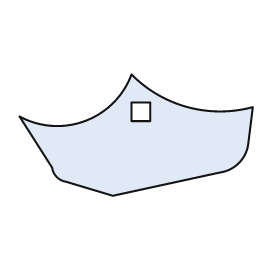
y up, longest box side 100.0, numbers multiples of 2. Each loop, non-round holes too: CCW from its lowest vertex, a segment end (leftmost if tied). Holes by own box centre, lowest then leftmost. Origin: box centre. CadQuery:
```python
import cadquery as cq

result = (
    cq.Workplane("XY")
    .moveTo(-10.0, -26.0)
    .lineTo(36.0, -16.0)
    .threePointArc((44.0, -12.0), (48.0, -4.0))
    .lineTo(50.0, 12.0)
    .threePointArc((22.0, 12.0), (-2.0, 26.0))
    .threePointArc((-22.0, 6.0), (-50.0, 8.0))
    .lineTo(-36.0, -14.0)
    .threePointArc((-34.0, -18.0), (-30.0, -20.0))
    .close()
    .moveTo(-2.0, 6.0)
    .lineTo(6.0, 6.0)
    .lineTo(6.0, 14.0)
    .lineTo(-2.0, 14.0)
    .close()
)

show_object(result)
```